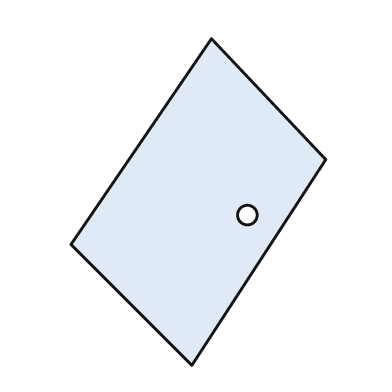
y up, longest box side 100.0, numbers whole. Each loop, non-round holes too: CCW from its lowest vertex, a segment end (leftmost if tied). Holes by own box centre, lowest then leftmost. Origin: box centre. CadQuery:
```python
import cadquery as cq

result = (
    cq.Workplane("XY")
    .moveTo(-2.0, -50.0)
    .lineTo(39.0, 13.0)
    .lineTo(4.0, 50.0)
    .lineTo(-39.0, -13.0)
    .close()
    .moveTo(15.0, -4.0)
    .circle(3.0)
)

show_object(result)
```